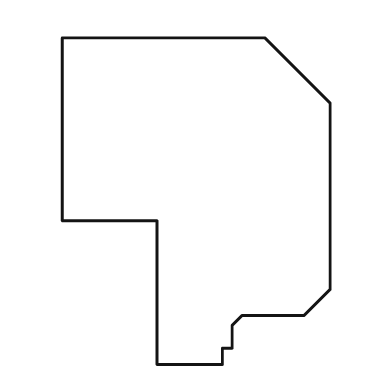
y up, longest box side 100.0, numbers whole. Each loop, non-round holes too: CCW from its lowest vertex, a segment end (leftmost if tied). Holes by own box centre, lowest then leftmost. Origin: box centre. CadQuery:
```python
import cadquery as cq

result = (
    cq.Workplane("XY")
    .moveTo(-12.0, -50.0)
    .lineTo(8.0, -50.0)
    .lineTo(8.0, -45.0)
    .lineTo(11.0, -45.0)
    .lineTo(11.0, -38.0)
    .lineTo(14.0, -35.0)
    .lineTo(33.0, -35.0)
    .lineTo(41.0, -27.0)
    .lineTo(41.0, 30.0)
    .lineTo(21.0, 50.0)
    .lineTo(-41.0, 50.0)
    .lineTo(-41.0, -6.0)
    .lineTo(-12.0, -6.0)
    .close()
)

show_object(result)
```